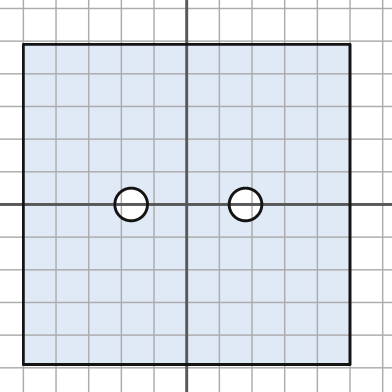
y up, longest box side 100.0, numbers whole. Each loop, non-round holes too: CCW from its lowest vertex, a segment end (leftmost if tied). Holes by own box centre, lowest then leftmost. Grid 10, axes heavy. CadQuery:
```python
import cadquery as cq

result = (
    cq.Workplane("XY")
    .moveTo(-50.0, -49.0)
    .lineTo(50.0, -49.0)
    .lineTo(50.0, 49.0)
    .lineTo(-50.0, 49.0)
    .close()
    .moveTo(-17.0, 0.0)
    .circle(5.0)
    .moveTo(18.0, 0.0)
    .circle(5.0)
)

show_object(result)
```